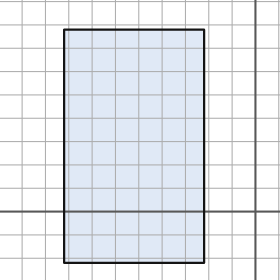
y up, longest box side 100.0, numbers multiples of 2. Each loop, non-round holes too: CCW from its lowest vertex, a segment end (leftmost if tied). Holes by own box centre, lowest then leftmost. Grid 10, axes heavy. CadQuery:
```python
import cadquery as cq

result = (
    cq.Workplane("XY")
    .moveTo(-82.0, -22.0)
    .lineTo(-22.0, -22.0)
    .lineTo(-22.0, 78.0)
    .lineTo(-82.0, 78.0)
    .close()
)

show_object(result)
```